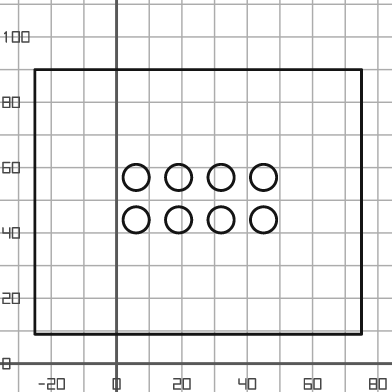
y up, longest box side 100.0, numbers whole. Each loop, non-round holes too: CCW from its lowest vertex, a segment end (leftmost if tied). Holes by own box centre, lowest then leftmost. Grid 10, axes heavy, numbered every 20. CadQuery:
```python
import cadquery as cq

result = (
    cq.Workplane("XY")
    .moveTo(-25.0, 9.0)
    .lineTo(75.0, 9.0)
    .lineTo(75.0, 90.0)
    .lineTo(-25.0, 90.0)
    .close()
    .moveTo(6.0, 44.0)
    .circle(4.0)
    .moveTo(19.0, 44.0)
    .circle(4.0)
    .moveTo(32.0, 44.0)
    .circle(4.0)
    .moveTo(45.0, 44.0)
    .circle(4.0)
    .moveTo(6.0, 57.0)
    .circle(4.0)
    .moveTo(19.0, 57.0)
    .circle(4.0)
    .moveTo(32.0, 57.0)
    .circle(4.0)
    .moveTo(45.0, 57.0)
    .circle(4.0)
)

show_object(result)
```